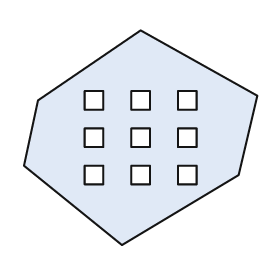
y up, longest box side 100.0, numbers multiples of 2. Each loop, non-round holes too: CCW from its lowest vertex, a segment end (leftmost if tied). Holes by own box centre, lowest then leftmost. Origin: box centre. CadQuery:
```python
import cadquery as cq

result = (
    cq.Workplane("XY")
    .moveTo(-8.0, -46.0)
    .lineTo(42.0, -16.0)
    .lineTo(50.0, 18.0)
    .lineTo(0.0, 46.0)
    .lineTo(-44.0, 16.0)
    .lineTo(-50.0, -12.0)
    .close()
    .moveTo(-24.0, -20.0)
    .lineTo(-16.0, -20.0)
    .lineTo(-16.0, -12.0)
    .lineTo(-24.0, -12.0)
    .close()
    .moveTo(-4.0, -20.0)
    .lineTo(4.0, -20.0)
    .lineTo(4.0, -12.0)
    .lineTo(-4.0, -12.0)
    .close()
    .moveTo(16.0, -20.0)
    .lineTo(24.0, -20.0)
    .lineTo(24.0, -12.0)
    .lineTo(16.0, -12.0)
    .close()
    .moveTo(-24.0, -4.0)
    .lineTo(-16.0, -4.0)
    .lineTo(-16.0, 4.0)
    .lineTo(-24.0, 4.0)
    .close()
    .moveTo(-4.0, -4.0)
    .lineTo(4.0, -4.0)
    .lineTo(4.0, 4.0)
    .lineTo(-4.0, 4.0)
    .close()
    .moveTo(16.0, -4.0)
    .lineTo(24.0, -4.0)
    .lineTo(24.0, 4.0)
    .lineTo(16.0, 4.0)
    .close()
    .moveTo(-24.0, 12.0)
    .lineTo(-16.0, 12.0)
    .lineTo(-16.0, 20.0)
    .lineTo(-24.0, 20.0)
    .close()
    .moveTo(-4.0, 12.0)
    .lineTo(4.0, 12.0)
    .lineTo(4.0, 20.0)
    .lineTo(-4.0, 20.0)
    .close()
    .moveTo(16.0, 12.0)
    .lineTo(24.0, 12.0)
    .lineTo(24.0, 20.0)
    .lineTo(16.0, 20.0)
    .close()
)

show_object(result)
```